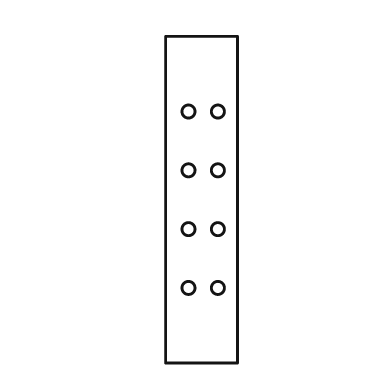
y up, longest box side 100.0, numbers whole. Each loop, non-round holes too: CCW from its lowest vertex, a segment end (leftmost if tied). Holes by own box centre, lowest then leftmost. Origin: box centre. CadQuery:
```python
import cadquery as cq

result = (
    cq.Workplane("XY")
    .moveTo(-11.0, -50.0)
    .lineTo(11.0, -50.0)
    .lineTo(11.0, 50.0)
    .lineTo(-11.0, 50.0)
    .close()
    .moveTo(-4.0, -27.0)
    .circle(2.0)
    .moveTo(5.0, -27.0)
    .circle(2.0)
    .moveTo(-4.0, -9.0)
    .circle(2.0)
    .moveTo(5.0, -9.0)
    .circle(2.0)
    .moveTo(-4.0, 9.0)
    .circle(2.0)
    .moveTo(5.0, 9.0)
    .circle(2.0)
    .moveTo(-4.0, 27.0)
    .circle(2.0)
    .moveTo(5.0, 27.0)
    .circle(2.0)
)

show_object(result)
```